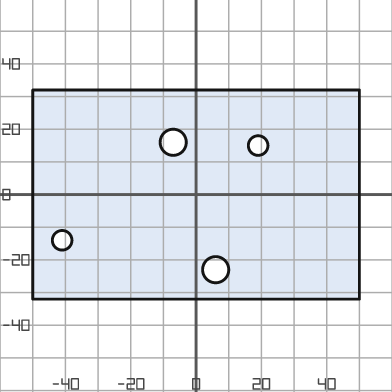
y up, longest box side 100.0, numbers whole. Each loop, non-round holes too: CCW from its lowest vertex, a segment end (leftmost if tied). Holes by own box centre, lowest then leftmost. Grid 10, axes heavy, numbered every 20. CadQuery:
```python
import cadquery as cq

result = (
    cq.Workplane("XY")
    .moveTo(-50.0, -32.0)
    .lineTo(50.0, -32.0)
    .lineTo(50.0, 32.0)
    .lineTo(-50.0, 32.0)
    .close()
    .moveTo(6.0, -23.0)
    .circle(4.0)
    .moveTo(-41.0, -14.0)
    .circle(3.0)
    .moveTo(19.0, 15.0)
    .circle(3.0)
    .moveTo(-7.0, 16.0)
    .circle(4.0)
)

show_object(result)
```